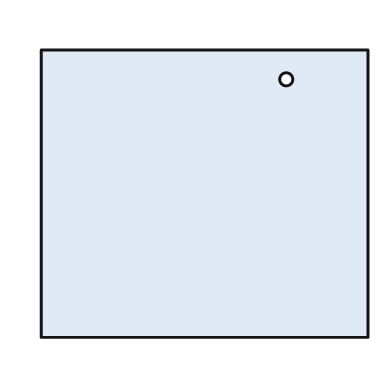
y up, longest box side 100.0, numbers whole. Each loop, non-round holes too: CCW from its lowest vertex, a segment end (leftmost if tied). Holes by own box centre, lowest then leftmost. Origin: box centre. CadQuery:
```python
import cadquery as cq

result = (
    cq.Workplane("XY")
    .moveTo(-50.0, -44.0)
    .lineTo(50.0, -44.0)
    .lineTo(50.0, 44.0)
    .lineTo(-50.0, 44.0)
    .close()
    .moveTo(25.0, 35.0)
    .circle(2.0)
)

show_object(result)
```